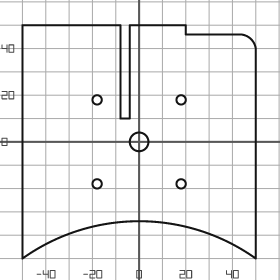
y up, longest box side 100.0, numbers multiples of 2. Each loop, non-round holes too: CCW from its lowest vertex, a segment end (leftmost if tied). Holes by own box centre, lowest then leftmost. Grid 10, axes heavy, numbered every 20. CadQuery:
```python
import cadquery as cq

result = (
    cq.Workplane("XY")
    .moveTo(-50.0, -50.0)
    .threePointArc((0.0, -34.0), (50.0, -50.0))
    .lineTo(50.0, 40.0)
    .threePointArc((48.0, 44.0), (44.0, 46.0))
    .lineTo(20.0, 46.0)
    .lineTo(20.0, 50.0)
    .lineTo(-4.0, 50.0)
    .lineTo(-4.0, 10.0)
    .lineTo(-8.0, 10.0)
    .lineTo(-8.0, 50.0)
    .lineTo(-50.0, 50.0)
    .close()
    .moveTo(-18.0, -18.0)
    .circle(2.0)
    .moveTo(18.0, -18.0)
    .circle(2.0)
    .moveTo(0.0, 0.0)
    .circle(4.0)
    .moveTo(-18.0, 18.0)
    .circle(2.0)
    .moveTo(18.0, 18.0)
    .circle(2.0)
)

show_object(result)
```